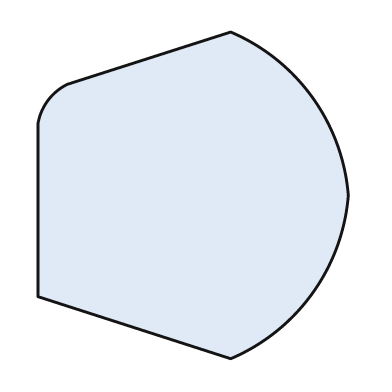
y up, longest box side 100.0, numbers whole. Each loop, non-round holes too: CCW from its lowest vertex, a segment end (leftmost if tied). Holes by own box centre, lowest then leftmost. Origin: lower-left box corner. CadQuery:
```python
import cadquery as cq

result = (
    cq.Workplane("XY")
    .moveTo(59.0, 0.0)
    .threePointArc((84.0, 20.0), (95.0, 50.0))
    .threePointArc((84.0, 80.0), (59.0, 100.0))
    .lineTo(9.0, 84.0)
    .threePointArc((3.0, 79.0), (0.0, 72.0))
    .lineTo(0.0, 19.0)
    .close()
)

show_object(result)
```